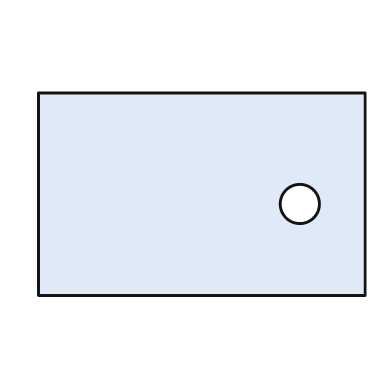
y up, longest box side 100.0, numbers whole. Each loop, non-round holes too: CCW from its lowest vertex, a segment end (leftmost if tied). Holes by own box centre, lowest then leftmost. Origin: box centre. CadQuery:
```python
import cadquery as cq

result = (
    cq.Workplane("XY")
    .moveTo(-50.0, -31.0)
    .lineTo(50.0, -31.0)
    .lineTo(50.0, 31.0)
    .lineTo(-50.0, 31.0)
    .close()
    .moveTo(30.0, -3.0)
    .circle(6.0)
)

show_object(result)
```